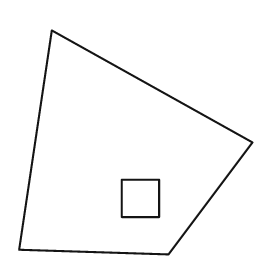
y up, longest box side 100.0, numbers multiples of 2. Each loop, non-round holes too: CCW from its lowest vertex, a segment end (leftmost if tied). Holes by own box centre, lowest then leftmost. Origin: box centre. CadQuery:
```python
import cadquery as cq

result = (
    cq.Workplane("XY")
    .moveTo(14.0, -48.0)
    .lineTo(50.0, 0.0)
    .lineTo(-36.0, 48.0)
    .lineTo(-50.0, -46.0)
    .close()
    .moveTo(-6.0, -32.0)
    .lineTo(10.0, -32.0)
    .lineTo(10.0, -16.0)
    .lineTo(-6.0, -16.0)
    .close()
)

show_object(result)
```